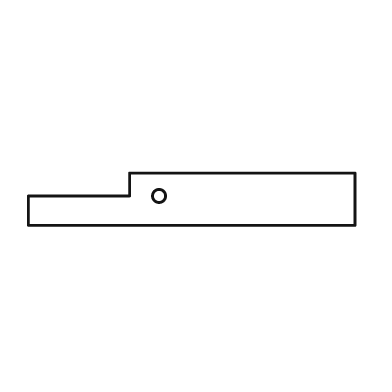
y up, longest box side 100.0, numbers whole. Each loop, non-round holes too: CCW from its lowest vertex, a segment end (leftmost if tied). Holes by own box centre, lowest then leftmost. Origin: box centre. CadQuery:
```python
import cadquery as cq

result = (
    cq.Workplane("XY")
    .moveTo(-50.0, -8.0)
    .lineTo(50.0, -8.0)
    .lineTo(50.0, 8.0)
    .lineTo(-19.0, 8.0)
    .lineTo(-19.0, 1.0)
    .lineTo(-50.0, 1.0)
    .close()
    .moveTo(-10.0, 1.0)
    .circle(2.0)
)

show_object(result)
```